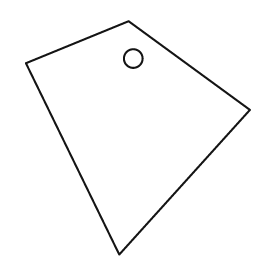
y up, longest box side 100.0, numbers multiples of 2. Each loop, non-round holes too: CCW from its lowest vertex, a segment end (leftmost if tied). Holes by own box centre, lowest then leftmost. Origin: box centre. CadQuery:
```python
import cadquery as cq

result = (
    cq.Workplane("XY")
    .moveTo(-8.0, -50.0)
    .lineTo(48.0, 12.0)
    .lineTo(-4.0, 50.0)
    .lineTo(-48.0, 32.0)
    .close()
    .moveTo(-2.0, 34.0)
    .circle(4.0)
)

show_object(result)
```